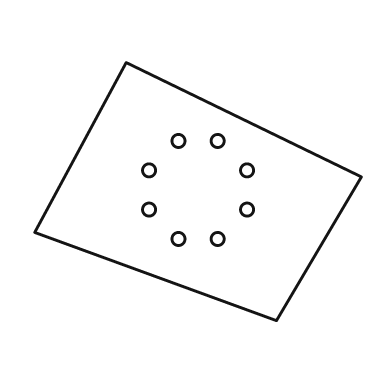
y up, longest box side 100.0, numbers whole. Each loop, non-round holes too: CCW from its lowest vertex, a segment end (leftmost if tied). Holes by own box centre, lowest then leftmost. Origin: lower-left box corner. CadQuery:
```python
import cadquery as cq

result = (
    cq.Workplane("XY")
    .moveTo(74.0, 0.0)
    .lineTo(100.0, 44.0)
    .lineTo(28.0, 79.0)
    .lineTo(0.0, 27.0)
    .close()
    .moveTo(44.0, 25.0)
    .circle(2.0)
    .moveTo(56.0, 25.0)
    .circle(2.0)
    .moveTo(35.0, 34.0)
    .circle(2.0)
    .moveTo(65.0, 34.0)
    .circle(2.0)
    .moveTo(35.0, 46.0)
    .circle(2.0)
    .moveTo(65.0, 46.0)
    .circle(2.0)
    .moveTo(44.0, 55.0)
    .circle(2.0)
    .moveTo(56.0, 55.0)
    .circle(2.0)
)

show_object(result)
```